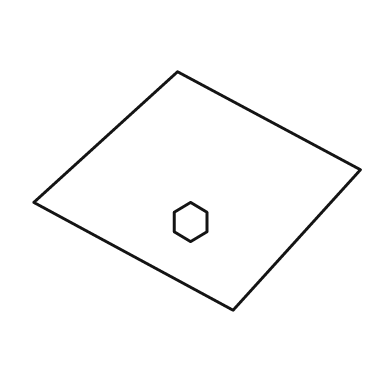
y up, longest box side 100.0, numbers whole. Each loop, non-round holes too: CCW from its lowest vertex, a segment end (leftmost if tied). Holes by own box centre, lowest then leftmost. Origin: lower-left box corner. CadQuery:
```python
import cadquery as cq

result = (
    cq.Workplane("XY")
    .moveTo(61.0, 0.0)
    .lineTo(100.0, 43.0)
    .lineTo(44.0, 73.0)
    .lineTo(0.0, 33.0)
    .close()
    .moveTo(48.0, 21.0)
    .lineTo(53.0, 24.0)
    .lineTo(53.0, 30.0)
    .lineTo(48.0, 33.0)
    .lineTo(43.0, 30.0)
    .lineTo(43.0, 24.0)
    .close()
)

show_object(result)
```